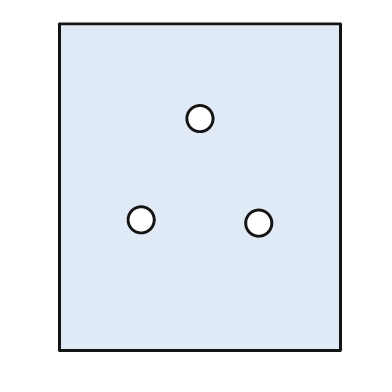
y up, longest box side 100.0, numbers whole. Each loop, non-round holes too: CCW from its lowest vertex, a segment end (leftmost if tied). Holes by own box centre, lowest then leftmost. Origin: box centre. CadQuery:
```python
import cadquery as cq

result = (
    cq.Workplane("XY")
    .moveTo(-43.0, -50.0)
    .lineTo(43.0, -50.0)
    .lineTo(43.0, 50.0)
    .lineTo(-43.0, 50.0)
    .close()
    .moveTo(18.0, -11.0)
    .circle(4.0)
    .moveTo(-18.0, -10.0)
    .circle(4.0)
    .moveTo(0.0, 21.0)
    .circle(4.0)
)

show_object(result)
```